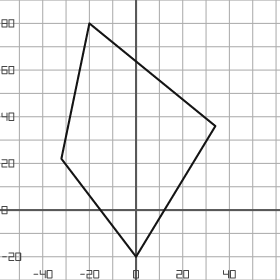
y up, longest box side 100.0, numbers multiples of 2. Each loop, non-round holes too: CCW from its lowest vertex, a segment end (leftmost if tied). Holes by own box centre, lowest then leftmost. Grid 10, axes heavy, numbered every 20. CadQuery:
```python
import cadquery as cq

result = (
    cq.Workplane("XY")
    .moveTo(0.0, -20.0)
    .lineTo(34.0, 36.0)
    .lineTo(-20.0, 80.0)
    .lineTo(-32.0, 22.0)
    .close()
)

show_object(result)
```